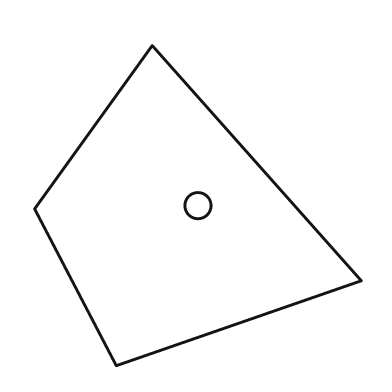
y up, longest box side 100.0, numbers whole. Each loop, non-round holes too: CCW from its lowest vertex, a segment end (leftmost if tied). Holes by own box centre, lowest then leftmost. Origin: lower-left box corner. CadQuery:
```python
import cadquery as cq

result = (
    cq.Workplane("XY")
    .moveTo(25.0, 0.0)
    .lineTo(100.0, 26.0)
    .lineTo(36.0, 98.0)
    .lineTo(0.0, 48.0)
    .close()
    .moveTo(50.0, 49.0)
    .circle(4.0)
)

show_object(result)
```